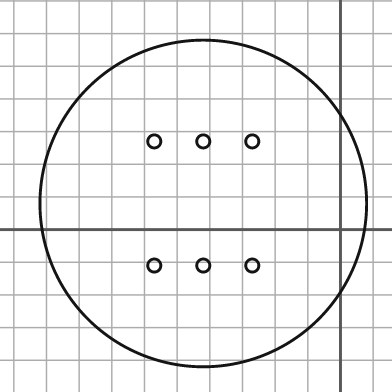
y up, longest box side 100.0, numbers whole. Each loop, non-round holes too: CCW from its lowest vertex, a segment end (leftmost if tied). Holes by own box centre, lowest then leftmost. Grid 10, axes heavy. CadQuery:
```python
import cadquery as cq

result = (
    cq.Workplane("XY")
    .moveTo(-42.0, 8.0)
    .circle(50.0)
    .moveTo(-57.0, -11.0)
    .circle(2.0)
    .moveTo(-42.0, -11.0)
    .circle(2.0)
    .moveTo(-27.0, -11.0)
    .circle(2.0)
    .moveTo(-57.0, 27.0)
    .circle(2.0)
    .moveTo(-42.0, 27.0)
    .circle(2.0)
    .moveTo(-27.0, 27.0)
    .circle(2.0)
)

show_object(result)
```